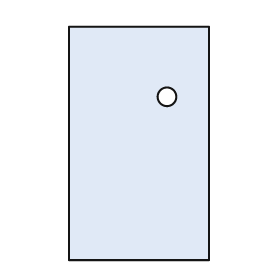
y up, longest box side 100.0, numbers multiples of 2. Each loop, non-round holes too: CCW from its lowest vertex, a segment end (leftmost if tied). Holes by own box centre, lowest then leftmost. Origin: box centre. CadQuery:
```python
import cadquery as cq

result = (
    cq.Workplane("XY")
    .moveTo(-30.0, -50.0)
    .lineTo(30.0, -50.0)
    .lineTo(30.0, 50.0)
    .lineTo(-30.0, 50.0)
    .close()
    .moveTo(12.0, 20.0)
    .circle(4.0)
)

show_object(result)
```